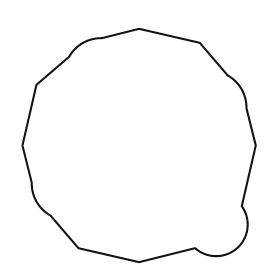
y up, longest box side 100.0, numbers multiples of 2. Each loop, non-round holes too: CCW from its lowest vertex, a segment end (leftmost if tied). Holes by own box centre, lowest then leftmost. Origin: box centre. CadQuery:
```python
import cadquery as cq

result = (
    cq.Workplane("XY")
    .moveTo(0.0, -50.0)
    .lineTo(24.0, -44.0)
    .threePointArc((42.0, -44.0), (44.0, -26.0))
    .lineTo(50.0, 0.0)
    .lineTo(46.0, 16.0)
    .threePointArc((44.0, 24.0), (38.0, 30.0))
    .lineTo(26.0, 44.0)
    .lineTo(0.0, 50.0)
    .lineTo(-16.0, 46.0)
    .threePointArc((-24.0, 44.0), (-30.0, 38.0))
    .lineTo(-44.0, 26.0)
    .lineTo(-50.0, 0.0)
    .lineTo(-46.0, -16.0)
    .threePointArc((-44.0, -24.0), (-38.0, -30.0))
    .lineTo(-26.0, -44.0)
    .close()
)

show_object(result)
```